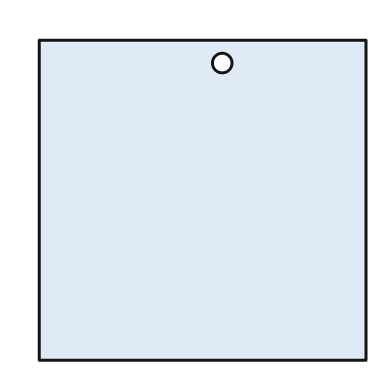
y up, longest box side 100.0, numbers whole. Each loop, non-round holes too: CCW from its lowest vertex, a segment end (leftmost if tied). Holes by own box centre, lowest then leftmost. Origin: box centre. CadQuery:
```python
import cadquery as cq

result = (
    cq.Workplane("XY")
    .moveTo(-50.0, -49.0)
    .lineTo(50.0, -49.0)
    .lineTo(50.0, 49.0)
    .lineTo(-50.0, 49.0)
    .close()
    .moveTo(6.0, 42.0)
    .circle(3.0)
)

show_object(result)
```